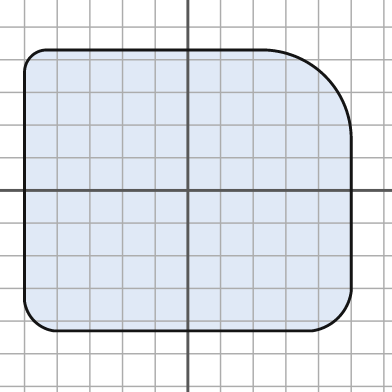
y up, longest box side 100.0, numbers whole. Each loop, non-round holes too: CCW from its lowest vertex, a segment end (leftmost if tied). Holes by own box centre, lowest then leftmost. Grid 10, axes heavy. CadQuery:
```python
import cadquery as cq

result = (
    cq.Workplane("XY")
    .moveTo(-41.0, -43.0)
    .lineTo(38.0, -43.0)
    .threePointArc((46.0, -39.0), (50.0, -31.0))
    .lineTo(50.0, 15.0)
    .threePointArc((42.0, 35.0), (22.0, 43.0))
    .lineTo(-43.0, 43.0)
    .threePointArc((-48.0, 41.0), (-50.0, 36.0))
    .lineTo(-50.0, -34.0)
    .threePointArc((-47.0, -40.0), (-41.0, -43.0))
    .close()
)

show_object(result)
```